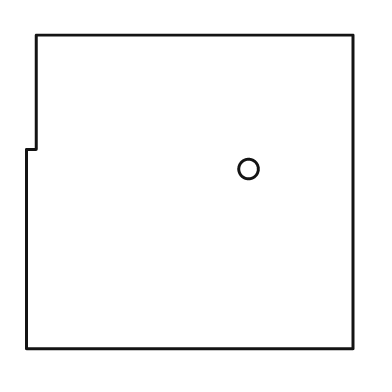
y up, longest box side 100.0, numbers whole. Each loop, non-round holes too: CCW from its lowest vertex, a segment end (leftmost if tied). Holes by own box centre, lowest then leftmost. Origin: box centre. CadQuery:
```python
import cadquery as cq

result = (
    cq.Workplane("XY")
    .moveTo(-50.0, -48.0)
    .lineTo(50.0, -48.0)
    .lineTo(50.0, 48.0)
    .lineTo(-47.0, 48.0)
    .lineTo(-47.0, 13.0)
    .lineTo(-50.0, 13.0)
    .close()
    .moveTo(18.0, 7.0)
    .circle(3.0)
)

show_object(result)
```